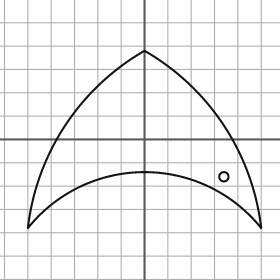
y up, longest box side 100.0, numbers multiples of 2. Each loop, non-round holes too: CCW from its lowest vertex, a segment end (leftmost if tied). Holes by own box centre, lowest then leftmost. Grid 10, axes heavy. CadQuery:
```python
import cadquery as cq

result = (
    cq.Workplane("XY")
    .moveTo(-50.0, -38.0)
    .threePointArc((0.0, -14.0), (50.0, -38.0))
    .threePointArc((34.0, 6.0), (0.0, 38.0))
    .threePointArc((-34.0, 6.0), (-50.0, -38.0))
    .close()
    .moveTo(34.0, -16.0)
    .circle(2.0)
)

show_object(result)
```